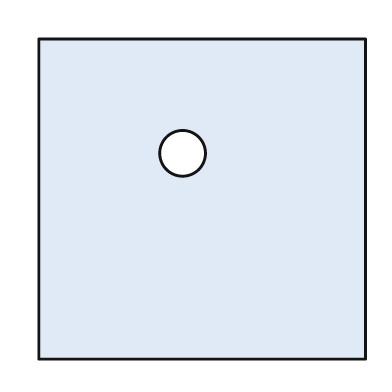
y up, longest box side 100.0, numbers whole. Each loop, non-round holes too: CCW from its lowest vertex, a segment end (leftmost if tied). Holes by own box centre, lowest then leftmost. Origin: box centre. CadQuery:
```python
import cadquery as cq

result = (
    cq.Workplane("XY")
    .moveTo(-50.0, -49.0)
    .lineTo(50.0, -49.0)
    .lineTo(50.0, 49.0)
    .lineTo(-50.0, 49.0)
    .close()
    .moveTo(-6.0, 14.0)
    .circle(7.0)
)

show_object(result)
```